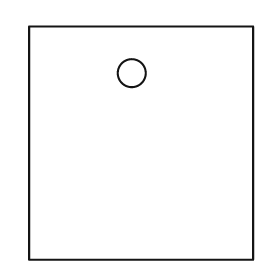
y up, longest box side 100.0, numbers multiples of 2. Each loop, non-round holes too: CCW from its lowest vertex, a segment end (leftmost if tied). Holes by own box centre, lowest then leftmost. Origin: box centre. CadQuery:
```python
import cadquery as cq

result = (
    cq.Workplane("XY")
    .moveTo(-48.0, -50.0)
    .lineTo(48.0, -50.0)
    .lineTo(48.0, 50.0)
    .lineTo(-48.0, 50.0)
    .close()
    .moveTo(-4.0, 30.0)
    .circle(6.0)
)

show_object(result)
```